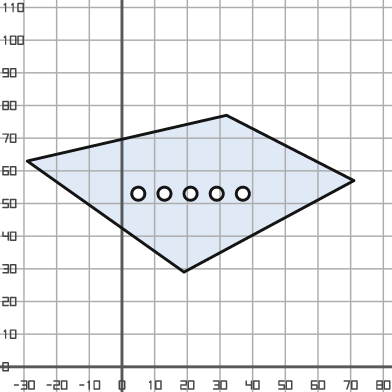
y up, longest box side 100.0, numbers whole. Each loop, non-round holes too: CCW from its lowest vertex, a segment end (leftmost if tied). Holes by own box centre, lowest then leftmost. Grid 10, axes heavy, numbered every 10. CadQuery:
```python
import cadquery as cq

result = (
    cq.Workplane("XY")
    .moveTo(19.0, 29.0)
    .lineTo(71.0, 57.0)
    .lineTo(32.0, 77.0)
    .lineTo(-29.0, 63.0)
    .close()
    .moveTo(5.0, 53.0)
    .circle(2.0)
    .moveTo(13.0, 53.0)
    .circle(2.0)
    .moveTo(21.0, 53.0)
    .circle(2.0)
    .moveTo(29.0, 53.0)
    .circle(2.0)
    .moveTo(37.0, 53.0)
    .circle(2.0)
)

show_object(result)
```